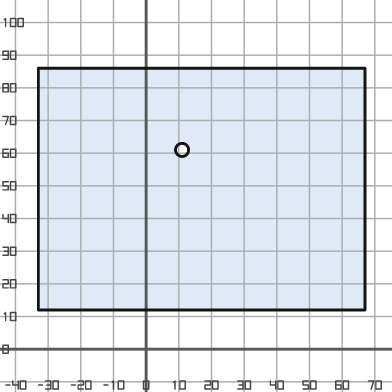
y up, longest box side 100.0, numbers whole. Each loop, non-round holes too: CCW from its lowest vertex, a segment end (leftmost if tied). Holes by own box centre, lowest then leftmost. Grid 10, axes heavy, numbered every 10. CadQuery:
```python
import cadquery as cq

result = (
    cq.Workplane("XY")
    .moveTo(-33.0, 12.0)
    .lineTo(67.0, 12.0)
    .lineTo(67.0, 86.0)
    .lineTo(-33.0, 86.0)
    .close()
    .moveTo(11.0, 61.0)
    .circle(2.0)
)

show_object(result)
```